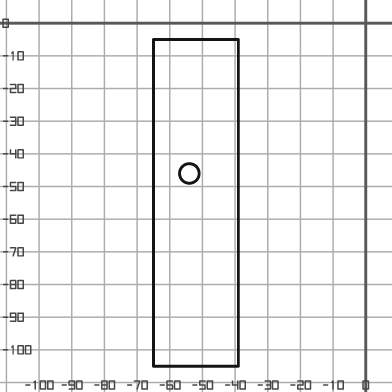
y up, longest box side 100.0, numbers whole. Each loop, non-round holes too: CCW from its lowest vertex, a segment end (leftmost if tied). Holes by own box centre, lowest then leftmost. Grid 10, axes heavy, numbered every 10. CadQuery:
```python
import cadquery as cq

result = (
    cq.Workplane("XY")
    .moveTo(-65.0, -105.0)
    .lineTo(-39.0, -105.0)
    .lineTo(-39.0, -5.0)
    .lineTo(-65.0, -5.0)
    .close()
    .moveTo(-54.0, -46.0)
    .circle(3.0)
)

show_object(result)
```